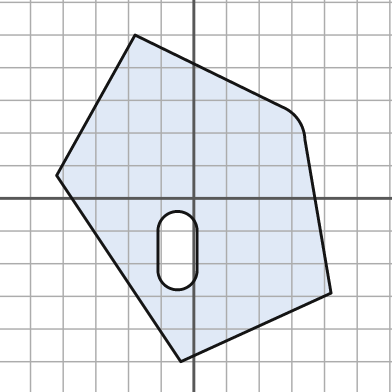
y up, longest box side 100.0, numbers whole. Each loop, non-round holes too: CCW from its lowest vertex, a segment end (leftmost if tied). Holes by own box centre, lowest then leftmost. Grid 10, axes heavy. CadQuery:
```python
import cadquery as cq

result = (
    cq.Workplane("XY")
    .moveTo(-4.0, -50.0)
    .lineTo(42.0, -29.0)
    .lineTo(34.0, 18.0)
    .threePointArc((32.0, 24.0), (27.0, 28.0))
    .lineTo(-18.0, 50.0)
    .lineTo(-42.0, 7.0)
    .close()
    .moveTo(-11.0, -22.0)
    .threePointArc((-5.0, -28.0), (1.0, -22.0))
    .lineTo(1.0, -10.0)
    .threePointArc((-5.0, -4.0), (-11.0, -10.0))
    .close()
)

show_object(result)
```